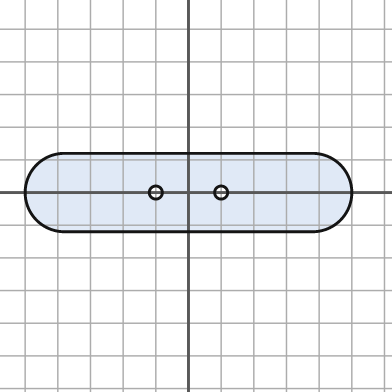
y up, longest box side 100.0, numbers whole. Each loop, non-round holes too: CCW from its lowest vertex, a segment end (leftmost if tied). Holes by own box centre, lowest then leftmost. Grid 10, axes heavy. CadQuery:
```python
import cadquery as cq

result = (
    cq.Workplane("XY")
    .moveTo(-38.0, -12.0)
    .lineTo(38.0, -12.0)
    .threePointArc((50.0, 0.0), (38.0, 12.0))
    .lineTo(-38.0, 12.0)
    .threePointArc((-50.0, 0.0), (-38.0, -12.0))
    .close()
    .moveTo(-10.0, 0.0)
    .circle(2.0)
    .moveTo(10.0, 0.0)
    .circle(2.0)
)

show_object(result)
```